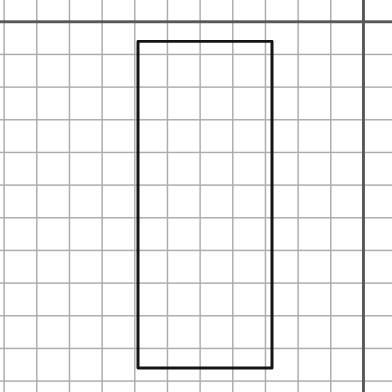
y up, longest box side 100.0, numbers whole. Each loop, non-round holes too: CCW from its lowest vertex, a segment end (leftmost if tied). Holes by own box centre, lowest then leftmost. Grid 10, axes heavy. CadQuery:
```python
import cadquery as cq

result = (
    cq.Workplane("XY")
    .moveTo(-69.0, -106.0)
    .lineTo(-28.0, -106.0)
    .lineTo(-28.0, -6.0)
    .lineTo(-69.0, -6.0)
    .close()
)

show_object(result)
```